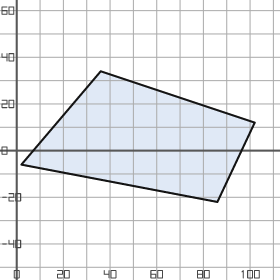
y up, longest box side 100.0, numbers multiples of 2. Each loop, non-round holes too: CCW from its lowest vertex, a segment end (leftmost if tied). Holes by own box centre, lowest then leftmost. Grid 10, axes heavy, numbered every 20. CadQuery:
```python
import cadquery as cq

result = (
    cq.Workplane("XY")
    .moveTo(86.0, -22.0)
    .lineTo(102.0, 12.0)
    .lineTo(36.0, 34.0)
    .lineTo(2.0, -6.0)
    .close()
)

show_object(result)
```